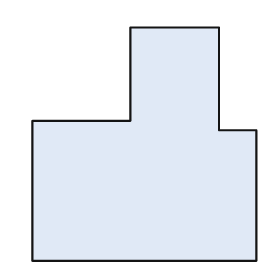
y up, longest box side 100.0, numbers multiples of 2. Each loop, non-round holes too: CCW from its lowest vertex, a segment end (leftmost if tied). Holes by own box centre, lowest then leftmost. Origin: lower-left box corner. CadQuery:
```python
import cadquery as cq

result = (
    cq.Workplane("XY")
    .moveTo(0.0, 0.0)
    .lineTo(96.0, 0.0)
    .lineTo(96.0, 56.0)
    .lineTo(80.0, 56.0)
    .lineTo(80.0, 100.0)
    .lineTo(42.0, 100.0)
    .lineTo(42.0, 60.0)
    .lineTo(0.0, 60.0)
    .close()
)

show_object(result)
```